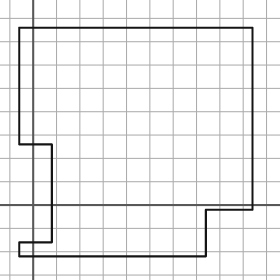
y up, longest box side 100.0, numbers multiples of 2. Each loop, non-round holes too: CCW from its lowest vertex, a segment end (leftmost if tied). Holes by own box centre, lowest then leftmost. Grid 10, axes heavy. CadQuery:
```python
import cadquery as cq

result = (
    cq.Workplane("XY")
    .moveTo(-6.0, -22.0)
    .lineTo(74.0, -22.0)
    .lineTo(74.0, -2.0)
    .lineTo(94.0, -2.0)
    .lineTo(94.0, 76.0)
    .lineTo(-6.0, 76.0)
    .lineTo(-6.0, 26.0)
    .lineTo(8.0, 26.0)
    .lineTo(8.0, -16.0)
    .lineTo(-6.0, -16.0)
    .close()
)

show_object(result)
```